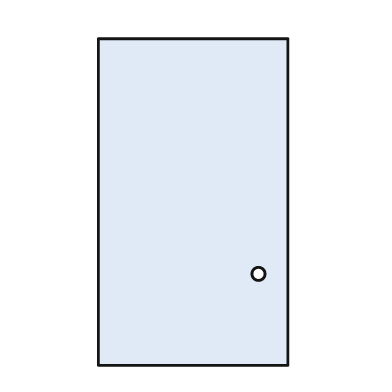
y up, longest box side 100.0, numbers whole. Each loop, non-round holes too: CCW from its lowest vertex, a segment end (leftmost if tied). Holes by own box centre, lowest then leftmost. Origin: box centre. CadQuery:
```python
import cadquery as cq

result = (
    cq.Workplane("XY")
    .moveTo(-29.0, -50.0)
    .lineTo(29.0, -50.0)
    .lineTo(29.0, 50.0)
    .lineTo(-29.0, 50.0)
    .close()
    .moveTo(20.0, -22.0)
    .circle(2.0)
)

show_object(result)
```